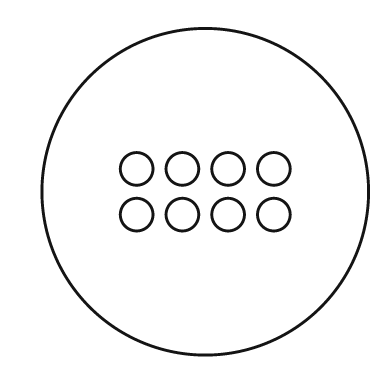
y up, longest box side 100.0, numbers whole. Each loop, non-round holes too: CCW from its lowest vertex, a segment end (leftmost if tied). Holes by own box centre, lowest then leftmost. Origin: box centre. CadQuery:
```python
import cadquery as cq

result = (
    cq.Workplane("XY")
    .moveTo(0.0, 0.0)
    .circle(50.0)
    .moveTo(-21.0, -7.0)
    .circle(5.0)
    .moveTo(-7.0, -7.0)
    .circle(5.0)
    .moveTo(7.0, -7.0)
    .circle(5.0)
    .moveTo(21.0, -7.0)
    .circle(5.0)
    .moveTo(-21.0, 7.0)
    .circle(5.0)
    .moveTo(-7.0, 7.0)
    .circle(5.0)
    .moveTo(7.0, 7.0)
    .circle(5.0)
    .moveTo(21.0, 7.0)
    .circle(5.0)
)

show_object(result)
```